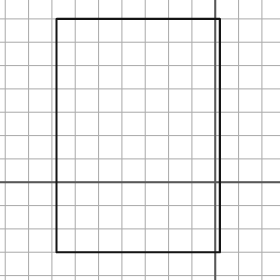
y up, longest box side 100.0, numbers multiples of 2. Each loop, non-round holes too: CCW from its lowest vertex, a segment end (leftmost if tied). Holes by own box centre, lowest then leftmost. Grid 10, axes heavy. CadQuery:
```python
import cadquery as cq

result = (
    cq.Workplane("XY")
    .moveTo(-68.0, -30.0)
    .lineTo(2.0, -30.0)
    .lineTo(2.0, 70.0)
    .lineTo(-68.0, 70.0)
    .close()
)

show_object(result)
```